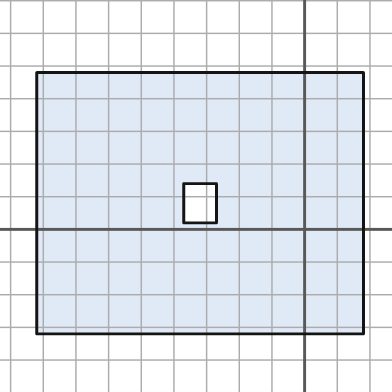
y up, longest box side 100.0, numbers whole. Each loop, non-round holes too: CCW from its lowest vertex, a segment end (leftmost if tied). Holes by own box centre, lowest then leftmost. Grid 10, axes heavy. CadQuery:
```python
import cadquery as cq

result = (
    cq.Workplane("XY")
    .moveTo(-82.0, -32.0)
    .lineTo(18.0, -32.0)
    .lineTo(18.0, 48.0)
    .lineTo(-82.0, 48.0)
    .close()
    .moveTo(-37.0, 2.0)
    .lineTo(-27.0, 2.0)
    .lineTo(-27.0, 14.0)
    .lineTo(-37.0, 14.0)
    .close()
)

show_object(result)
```